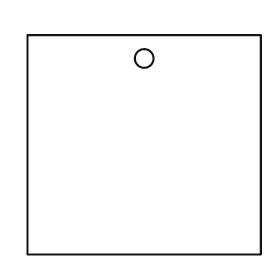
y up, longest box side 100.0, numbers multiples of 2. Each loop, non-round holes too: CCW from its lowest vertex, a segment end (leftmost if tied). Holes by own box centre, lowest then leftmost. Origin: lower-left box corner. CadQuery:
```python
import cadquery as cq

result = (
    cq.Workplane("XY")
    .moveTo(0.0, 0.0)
    .lineTo(100.0, 0.0)
    .lineTo(100.0, 94.0)
    .lineTo(0.0, 94.0)
    .close()
    .moveTo(50.0, 84.0)
    .circle(4.0)
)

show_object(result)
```